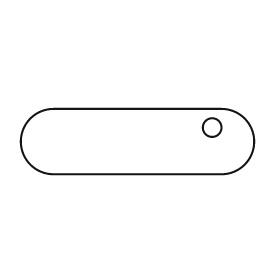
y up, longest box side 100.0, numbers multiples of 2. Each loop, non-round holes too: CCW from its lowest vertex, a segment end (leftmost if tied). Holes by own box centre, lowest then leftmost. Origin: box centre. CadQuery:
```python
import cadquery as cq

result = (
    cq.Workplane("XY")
    .moveTo(-36.0, -14.0)
    .lineTo(36.0, -14.0)
    .threePointArc((50.0, 0.0), (36.0, 14.0))
    .lineTo(-36.0, 14.0)
    .threePointArc((-50.0, 0.0), (-36.0, -14.0))
    .close()
    .moveTo(32.0, 6.0)
    .circle(4.0)
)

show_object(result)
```